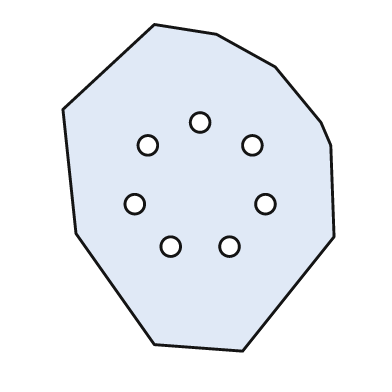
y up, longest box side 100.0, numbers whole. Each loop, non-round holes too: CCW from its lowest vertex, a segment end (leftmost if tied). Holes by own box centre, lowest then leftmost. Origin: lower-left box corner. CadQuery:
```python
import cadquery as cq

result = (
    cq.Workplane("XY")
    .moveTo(55.0, 0.0)
    .lineTo(83.0, 35.0)
    .lineTo(82.0, 63.0)
    .lineTo(79.0, 70.0)
    .lineTo(65.0, 87.0)
    .lineTo(47.0, 97.0)
    .lineTo(28.0, 100.0)
    .lineTo(0.0, 74.0)
    .lineTo(4.0, 36.0)
    .lineTo(28.0, 2.0)
    .close()
    .moveTo(33.0, 32.0)
    .circle(3.0)
    .moveTo(51.0, 32.0)
    .circle(3.0)
    .moveTo(22.0, 45.0)
    .circle(3.0)
    .moveTo(62.0, 45.0)
    .circle(3.0)
    .moveTo(26.0, 63.0)
    .circle(3.0)
    .moveTo(58.0, 63.0)
    .circle(3.0)
    .moveTo(42.0, 70.0)
    .circle(3.0)
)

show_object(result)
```